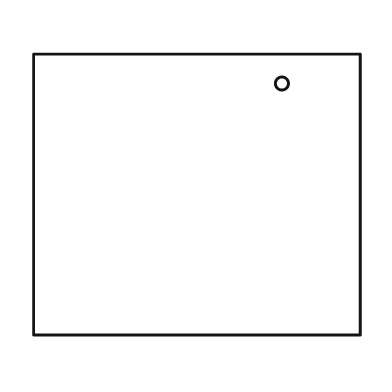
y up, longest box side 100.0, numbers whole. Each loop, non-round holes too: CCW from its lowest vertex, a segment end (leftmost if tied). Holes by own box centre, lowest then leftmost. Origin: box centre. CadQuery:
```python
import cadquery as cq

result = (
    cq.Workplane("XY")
    .moveTo(-50.0, -43.0)
    .lineTo(50.0, -43.0)
    .lineTo(50.0, 43.0)
    .lineTo(-50.0, 43.0)
    .close()
    .moveTo(26.0, 34.0)
    .circle(2.0)
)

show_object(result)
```